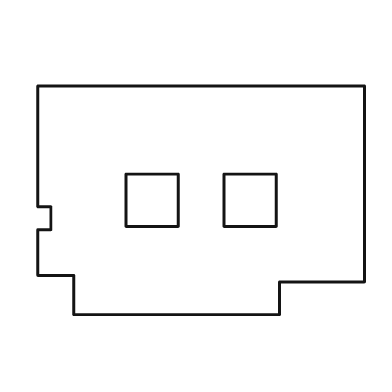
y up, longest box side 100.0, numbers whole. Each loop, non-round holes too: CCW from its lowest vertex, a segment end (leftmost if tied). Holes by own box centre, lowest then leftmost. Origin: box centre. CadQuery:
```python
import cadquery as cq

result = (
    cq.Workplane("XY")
    .moveTo(-39.0, -35.0)
    .lineTo(24.0, -35.0)
    .lineTo(24.0, -25.0)
    .lineTo(50.0, -25.0)
    .lineTo(50.0, 35.0)
    .lineTo(-50.0, 35.0)
    .lineTo(-50.0, -2.0)
    .lineTo(-46.0, -2.0)
    .lineTo(-46.0, -9.0)
    .lineTo(-50.0, -9.0)
    .lineTo(-50.0, -23.0)
    .lineTo(-39.0, -23.0)
    .close()
    .moveTo(-23.0, -8.0)
    .lineTo(-7.0, -8.0)
    .lineTo(-7.0, 8.0)
    .lineTo(-23.0, 8.0)
    .close()
    .moveTo(7.0, -8.0)
    .lineTo(23.0, -8.0)
    .lineTo(23.0, 8.0)
    .lineTo(7.0, 8.0)
    .close()
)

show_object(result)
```